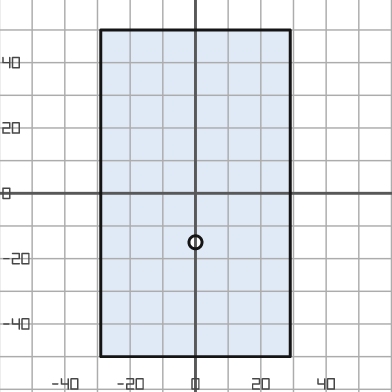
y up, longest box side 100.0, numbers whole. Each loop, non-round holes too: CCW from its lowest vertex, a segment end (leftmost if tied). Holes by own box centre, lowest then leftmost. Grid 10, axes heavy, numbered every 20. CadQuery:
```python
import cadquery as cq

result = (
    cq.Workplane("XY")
    .moveTo(-29.0, -50.0)
    .lineTo(29.0, -50.0)
    .lineTo(29.0, 50.0)
    .lineTo(-29.0, 50.0)
    .close()
    .moveTo(0.0, -15.0)
    .circle(2.0)
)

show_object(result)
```